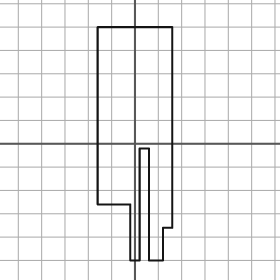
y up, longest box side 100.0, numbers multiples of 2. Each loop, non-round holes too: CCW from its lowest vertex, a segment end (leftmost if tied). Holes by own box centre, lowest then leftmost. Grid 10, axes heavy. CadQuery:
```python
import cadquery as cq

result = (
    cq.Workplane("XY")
    .moveTo(-2.0, -50.0)
    .lineTo(2.0, -50.0)
    .lineTo(2.0, -2.0)
    .lineTo(6.0, -2.0)
    .lineTo(6.0, -50.0)
    .lineTo(12.0, -50.0)
    .lineTo(12.0, -36.0)
    .lineTo(16.0, -36.0)
    .lineTo(16.0, 50.0)
    .lineTo(-16.0, 50.0)
    .lineTo(-16.0, -26.0)
    .lineTo(-2.0, -26.0)
    .close()
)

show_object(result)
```